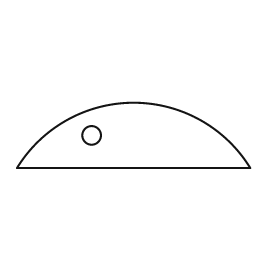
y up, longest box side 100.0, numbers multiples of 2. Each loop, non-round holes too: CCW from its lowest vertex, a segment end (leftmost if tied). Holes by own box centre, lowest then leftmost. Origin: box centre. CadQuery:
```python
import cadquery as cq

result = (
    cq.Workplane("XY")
    .moveTo(-50.0, -14.0)
    .lineTo(50.0, -14.0)
    .threePointArc((0.0, 14.0), (-50.0, -14.0))
    .close()
    .moveTo(-18.0, 0.0)
    .circle(4.0)
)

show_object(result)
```